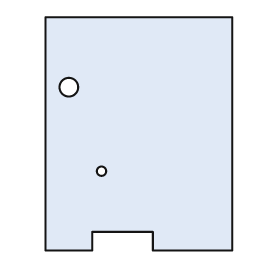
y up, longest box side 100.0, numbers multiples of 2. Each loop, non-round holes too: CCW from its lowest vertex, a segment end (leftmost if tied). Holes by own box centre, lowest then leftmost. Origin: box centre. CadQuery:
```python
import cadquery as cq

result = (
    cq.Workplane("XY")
    .moveTo(-40.0, -50.0)
    .lineTo(-20.0, -50.0)
    .lineTo(-20.0, -42.0)
    .lineTo(6.0, -42.0)
    .lineTo(6.0, -50.0)
    .lineTo(40.0, -50.0)
    .lineTo(40.0, 50.0)
    .lineTo(-40.0, 50.0)
    .close()
    .moveTo(-16.0, -16.0)
    .circle(2.0)
    .moveTo(-30.0, 20.0)
    .circle(4.0)
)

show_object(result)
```